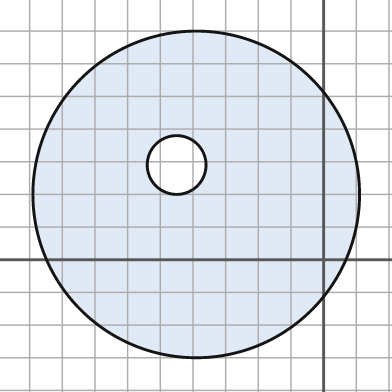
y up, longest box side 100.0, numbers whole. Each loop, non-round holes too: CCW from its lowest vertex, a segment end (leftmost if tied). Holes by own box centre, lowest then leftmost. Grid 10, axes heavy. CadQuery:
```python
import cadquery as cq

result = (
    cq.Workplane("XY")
    .moveTo(-39.0, 20.0)
    .circle(50.0)
    .moveTo(-45.0, 29.0)
    .circle(9.0)
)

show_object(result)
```